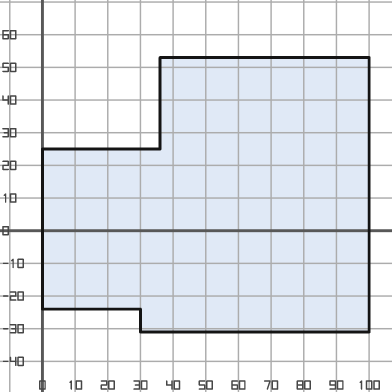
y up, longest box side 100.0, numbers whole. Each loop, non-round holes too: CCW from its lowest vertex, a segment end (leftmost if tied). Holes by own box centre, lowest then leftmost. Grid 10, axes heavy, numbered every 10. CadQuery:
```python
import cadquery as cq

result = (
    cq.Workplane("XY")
    .moveTo(30.0, -31.0)
    .lineTo(100.0, -31.0)
    .lineTo(100.0, 53.0)
    .lineTo(36.0, 53.0)
    .lineTo(36.0, 25.0)
    .lineTo(0.0, 25.0)
    .lineTo(0.0, -24.0)
    .lineTo(30.0, -24.0)
    .close()
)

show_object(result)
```